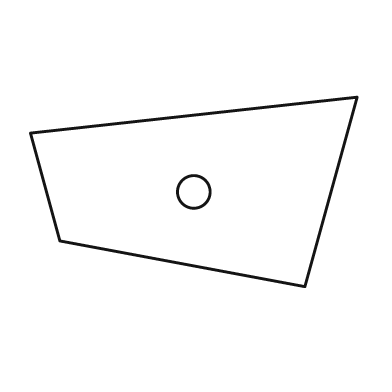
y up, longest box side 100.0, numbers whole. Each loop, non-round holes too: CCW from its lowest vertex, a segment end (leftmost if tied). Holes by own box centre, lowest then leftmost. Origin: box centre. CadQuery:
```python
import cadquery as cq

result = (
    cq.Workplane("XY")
    .moveTo(34.0, -29.0)
    .lineTo(50.0, 29.0)
    .lineTo(-50.0, 18.0)
    .lineTo(-41.0, -15.0)
    .close()
    .moveTo(0.0, 0.0)
    .circle(5.0)
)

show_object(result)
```